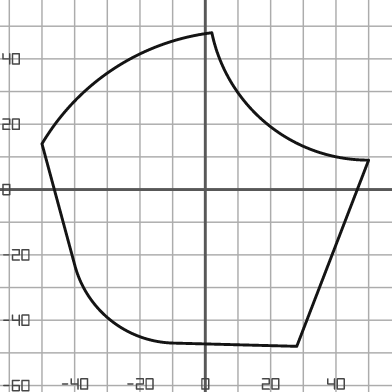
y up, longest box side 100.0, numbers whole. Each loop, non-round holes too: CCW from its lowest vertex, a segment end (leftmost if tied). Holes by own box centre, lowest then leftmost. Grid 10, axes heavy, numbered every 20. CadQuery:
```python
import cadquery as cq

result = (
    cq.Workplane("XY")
    .moveTo(28.0, -48.0)
    .lineTo(50.0, 9.0)
    .threePointArc((19.0, 20.0), (2.0, 48.0))
    .threePointArc((-28.0, 37.0), (-50.0, 14.0))
    .lineTo(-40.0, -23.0)
    .threePointArc((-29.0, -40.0), (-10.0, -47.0))
    .close()
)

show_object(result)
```